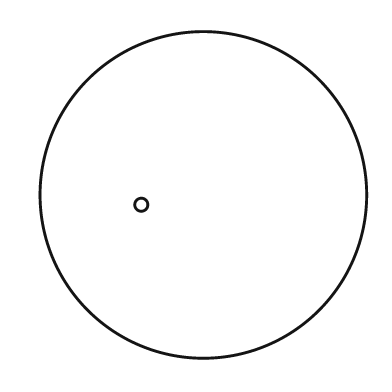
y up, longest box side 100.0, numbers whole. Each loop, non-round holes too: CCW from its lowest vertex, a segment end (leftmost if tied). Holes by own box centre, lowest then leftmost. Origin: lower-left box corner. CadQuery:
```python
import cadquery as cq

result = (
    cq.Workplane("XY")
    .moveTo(50.0, 50.0)
    .circle(50.0)
    .moveTo(31.0, 47.0)
    .circle(2.0)
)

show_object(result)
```